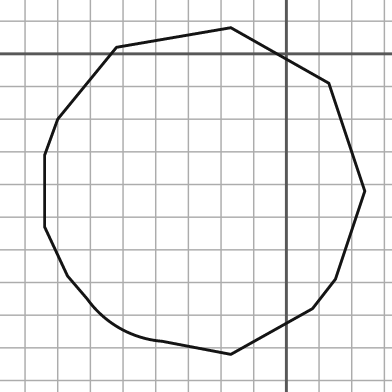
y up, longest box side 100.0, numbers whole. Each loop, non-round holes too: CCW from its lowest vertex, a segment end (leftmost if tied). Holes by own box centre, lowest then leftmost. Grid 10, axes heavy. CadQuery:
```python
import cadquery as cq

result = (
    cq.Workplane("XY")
    .moveTo(-17.0, -92.0)
    .lineTo(8.0, -78.0)
    .lineTo(15.0, -69.0)
    .lineTo(24.0, -42.0)
    .lineTo(13.0, -9.0)
    .lineTo(-17.0, 8.0)
    .lineTo(-52.0, 2.0)
    .lineTo(-70.0, -20.0)
    .lineTo(-74.0, -31.0)
    .lineTo(-74.0, -53.0)
    .lineTo(-67.0, -68.0)
    .lineTo(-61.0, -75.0)
    .threePointArc((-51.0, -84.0), (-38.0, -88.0))
    .close()
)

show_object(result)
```